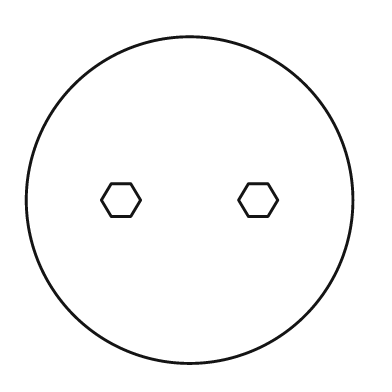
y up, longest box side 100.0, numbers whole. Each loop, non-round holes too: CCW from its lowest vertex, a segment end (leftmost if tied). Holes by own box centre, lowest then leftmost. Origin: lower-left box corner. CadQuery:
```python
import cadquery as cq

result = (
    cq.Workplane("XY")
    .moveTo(50.0, 50.0)
    .circle(50.0)
    .moveTo(26.0, 45.0)
    .lineTo(32.0, 45.0)
    .lineTo(35.0, 50.0)
    .lineTo(32.0, 55.0)
    .lineTo(26.0, 55.0)
    .lineTo(23.0, 50.0)
    .close()
    .moveTo(68.0, 45.0)
    .lineTo(74.0, 45.0)
    .lineTo(77.0, 50.0)
    .lineTo(74.0, 55.0)
    .lineTo(68.0, 55.0)
    .lineTo(65.0, 50.0)
    .close()
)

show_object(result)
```